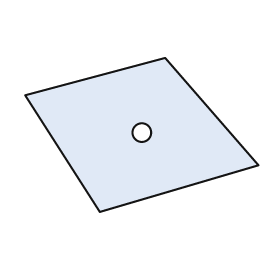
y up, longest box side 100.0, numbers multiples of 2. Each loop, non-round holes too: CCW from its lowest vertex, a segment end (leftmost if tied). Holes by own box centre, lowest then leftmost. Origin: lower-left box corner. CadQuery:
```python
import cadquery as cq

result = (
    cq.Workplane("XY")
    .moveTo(32.0, 0.0)
    .lineTo(100.0, 20.0)
    .lineTo(60.0, 66.0)
    .lineTo(0.0, 50.0)
    .close()
    .moveTo(50.0, 34.0)
    .circle(4.0)
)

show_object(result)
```